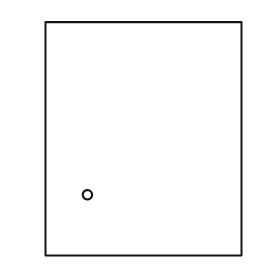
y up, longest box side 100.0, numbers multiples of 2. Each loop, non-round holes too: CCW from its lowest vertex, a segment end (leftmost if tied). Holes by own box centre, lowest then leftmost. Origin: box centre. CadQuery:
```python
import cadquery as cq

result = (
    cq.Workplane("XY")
    .moveTo(-42.0, -50.0)
    .lineTo(42.0, -50.0)
    .lineTo(42.0, 50.0)
    .lineTo(-42.0, 50.0)
    .close()
    .moveTo(-24.0, -24.0)
    .circle(2.0)
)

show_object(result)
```